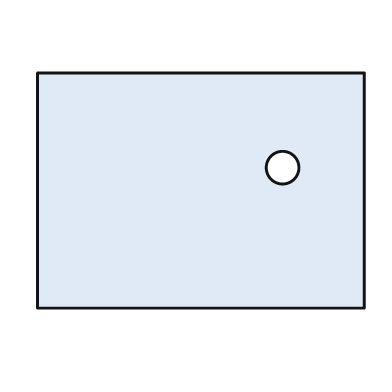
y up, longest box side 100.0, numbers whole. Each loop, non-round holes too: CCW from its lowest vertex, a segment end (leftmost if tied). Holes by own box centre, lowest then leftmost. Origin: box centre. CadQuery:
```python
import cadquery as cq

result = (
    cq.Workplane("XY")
    .moveTo(-50.0, -36.0)
    .lineTo(50.0, -36.0)
    .lineTo(50.0, 36.0)
    .lineTo(-50.0, 36.0)
    .close()
    .moveTo(25.0, 7.0)
    .circle(5.0)
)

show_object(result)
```